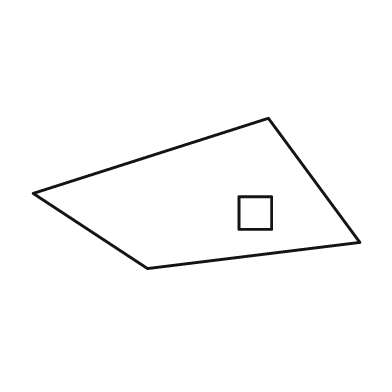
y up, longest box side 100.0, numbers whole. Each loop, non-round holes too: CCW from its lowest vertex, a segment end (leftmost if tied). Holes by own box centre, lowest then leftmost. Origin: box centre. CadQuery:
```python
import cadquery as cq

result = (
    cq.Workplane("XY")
    .moveTo(-15.0, -23.0)
    .lineTo(50.0, -15.0)
    .lineTo(22.0, 23.0)
    .lineTo(-50.0, 0.0)
    .close()
    .moveTo(13.0, -11.0)
    .lineTo(23.0, -11.0)
    .lineTo(23.0, -1.0)
    .lineTo(13.0, -1.0)
    .close()
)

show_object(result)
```